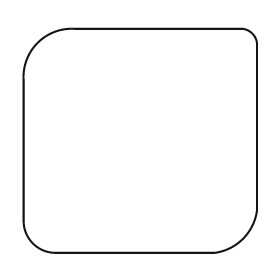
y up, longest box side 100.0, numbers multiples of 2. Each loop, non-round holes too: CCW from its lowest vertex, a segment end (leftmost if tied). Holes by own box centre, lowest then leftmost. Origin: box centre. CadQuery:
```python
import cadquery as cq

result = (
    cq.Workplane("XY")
    .moveTo(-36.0, -48.0)
    .lineTo(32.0, -48.0)
    .threePointArc((44.0, -42.0), (50.0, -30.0))
    .lineTo(50.0, 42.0)
    .threePointArc((48.0, 46.0), (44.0, 48.0))
    .lineTo(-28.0, 48.0)
    .threePointArc((-44.0, 42.0), (-50.0, 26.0))
    .lineTo(-50.0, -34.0)
    .threePointArc((-46.0, -44.0), (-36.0, -48.0))
    .close()
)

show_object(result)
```